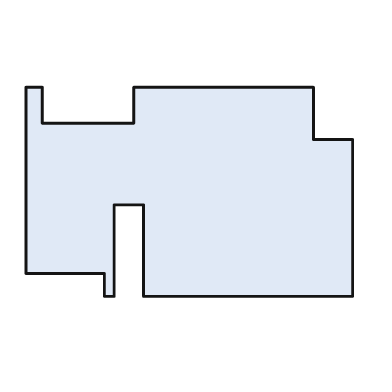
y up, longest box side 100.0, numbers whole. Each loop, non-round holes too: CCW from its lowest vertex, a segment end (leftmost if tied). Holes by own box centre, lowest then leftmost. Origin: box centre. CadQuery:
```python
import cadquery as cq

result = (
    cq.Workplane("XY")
    .moveTo(-26.0, -32.0)
    .lineTo(-23.0, -32.0)
    .lineTo(-23.0, -4.0)
    .lineTo(-14.0, -4.0)
    .lineTo(-14.0, -32.0)
    .lineTo(50.0, -32.0)
    .lineTo(50.0, 16.0)
    .lineTo(38.0, 16.0)
    .lineTo(38.0, 32.0)
    .lineTo(-17.0, 32.0)
    .lineTo(-17.0, 21.0)
    .lineTo(-45.0, 21.0)
    .lineTo(-45.0, 32.0)
    .lineTo(-50.0, 32.0)
    .lineTo(-50.0, -25.0)
    .lineTo(-26.0, -25.0)
    .close()
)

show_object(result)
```